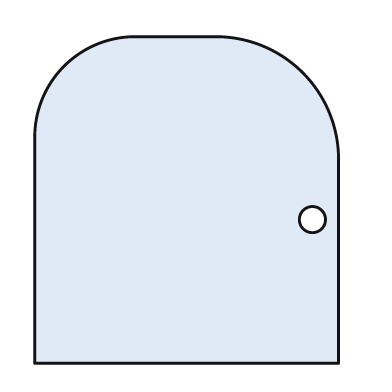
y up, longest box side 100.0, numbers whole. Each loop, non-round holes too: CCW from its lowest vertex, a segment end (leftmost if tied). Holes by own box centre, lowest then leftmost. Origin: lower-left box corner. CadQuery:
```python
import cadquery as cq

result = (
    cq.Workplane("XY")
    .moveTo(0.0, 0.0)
    .lineTo(93.0, 0.0)
    .lineTo(93.0, 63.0)
    .threePointArc((82.0, 89.0), (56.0, 100.0))
    .lineTo(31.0, 100.0)
    .threePointArc((9.0, 91.0), (0.0, 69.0))
    .close()
    .moveTo(85.0, 44.0)
    .circle(4.0)
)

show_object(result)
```